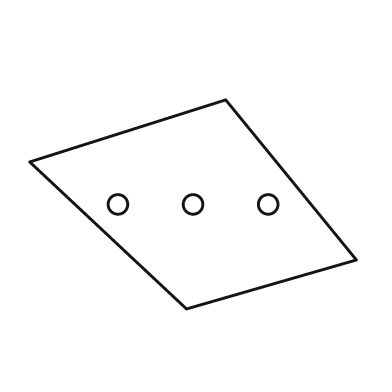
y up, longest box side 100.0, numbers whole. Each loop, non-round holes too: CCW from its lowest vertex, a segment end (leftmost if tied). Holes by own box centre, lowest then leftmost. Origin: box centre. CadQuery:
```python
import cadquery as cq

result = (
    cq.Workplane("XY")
    .moveTo(-2.0, -32.0)
    .lineTo(50.0, -17.0)
    .lineTo(10.0, 32.0)
    .lineTo(-50.0, 13.0)
    .close()
    .moveTo(-23.0, 0.0)
    .circle(3.0)
    .moveTo(0.0, 0.0)
    .circle(3.0)
    .moveTo(23.0, 0.0)
    .circle(3.0)
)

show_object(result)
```